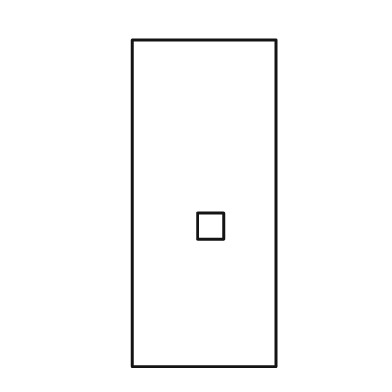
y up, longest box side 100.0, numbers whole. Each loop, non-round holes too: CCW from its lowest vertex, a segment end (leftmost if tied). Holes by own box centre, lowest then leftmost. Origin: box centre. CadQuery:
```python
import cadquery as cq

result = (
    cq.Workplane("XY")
    .moveTo(-22.0, -50.0)
    .lineTo(22.0, -50.0)
    .lineTo(22.0, 50.0)
    .lineTo(-22.0, 50.0)
    .close()
    .moveTo(-2.0, -11.0)
    .lineTo(6.0, -11.0)
    .lineTo(6.0, -3.0)
    .lineTo(-2.0, -3.0)
    .close()
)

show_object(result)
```